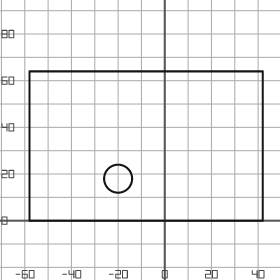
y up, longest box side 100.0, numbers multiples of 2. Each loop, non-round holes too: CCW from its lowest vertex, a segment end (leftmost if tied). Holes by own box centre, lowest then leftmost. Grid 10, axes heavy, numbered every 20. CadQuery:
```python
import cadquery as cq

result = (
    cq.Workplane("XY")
    .moveTo(-58.0, 0.0)
    .lineTo(42.0, 0.0)
    .lineTo(42.0, 64.0)
    .lineTo(-58.0, 64.0)
    .close()
    .moveTo(-20.0, 18.0)
    .circle(6.0)
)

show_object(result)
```